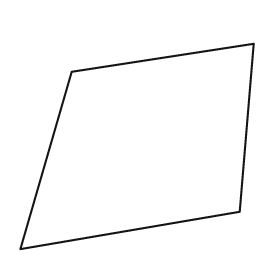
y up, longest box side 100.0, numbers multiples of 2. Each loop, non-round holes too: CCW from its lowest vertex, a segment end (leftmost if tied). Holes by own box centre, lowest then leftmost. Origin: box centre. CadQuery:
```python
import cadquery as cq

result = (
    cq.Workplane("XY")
    .moveTo(-50.0, -44.0)
    .lineTo(44.0, -28.0)
    .lineTo(50.0, 44.0)
    .lineTo(-28.0, 32.0)
    .close()
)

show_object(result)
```